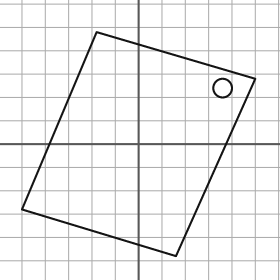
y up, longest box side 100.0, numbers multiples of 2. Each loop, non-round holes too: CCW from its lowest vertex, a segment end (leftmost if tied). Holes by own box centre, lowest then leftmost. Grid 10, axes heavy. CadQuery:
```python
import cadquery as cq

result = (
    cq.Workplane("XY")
    .moveTo(16.0, -48.0)
    .lineTo(50.0, 28.0)
    .lineTo(-18.0, 48.0)
    .lineTo(-50.0, -28.0)
    .close()
    .moveTo(36.0, 24.0)
    .circle(4.0)
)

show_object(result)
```